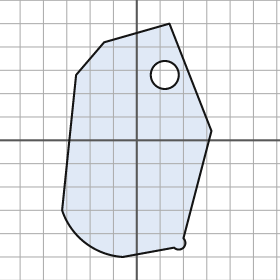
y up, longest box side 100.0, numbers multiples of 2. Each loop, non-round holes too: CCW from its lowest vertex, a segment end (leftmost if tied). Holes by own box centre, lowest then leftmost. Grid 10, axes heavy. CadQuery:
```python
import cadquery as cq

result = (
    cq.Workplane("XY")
    .moveTo(-6.0, -50.0)
    .lineTo(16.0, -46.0)
    .threePointArc((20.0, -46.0), (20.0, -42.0))
    .lineTo(32.0, 4.0)
    .lineTo(14.0, 50.0)
    .lineTo(-14.0, 42.0)
    .lineTo(-26.0, 28.0)
    .lineTo(-32.0, -30.0)
    .threePointArc((-22.0, -44.0), (-6.0, -50.0))
    .close()
    .moveTo(12.0, 28.0)
    .circle(6.0)
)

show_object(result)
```